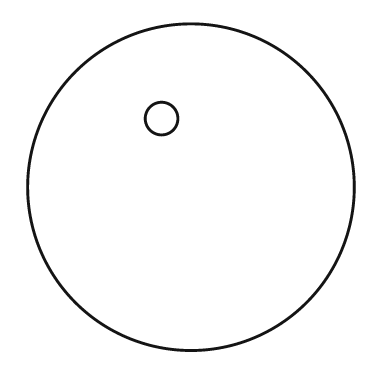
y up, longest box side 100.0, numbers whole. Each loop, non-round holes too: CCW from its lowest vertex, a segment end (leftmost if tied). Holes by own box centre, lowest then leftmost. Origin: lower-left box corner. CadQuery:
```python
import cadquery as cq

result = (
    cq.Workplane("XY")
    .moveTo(50.0, 50.0)
    .circle(50.0)
    .moveTo(41.0, 71.0)
    .circle(5.0)
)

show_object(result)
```